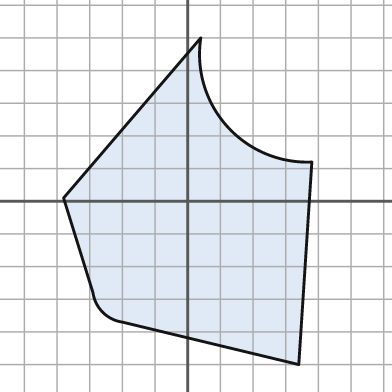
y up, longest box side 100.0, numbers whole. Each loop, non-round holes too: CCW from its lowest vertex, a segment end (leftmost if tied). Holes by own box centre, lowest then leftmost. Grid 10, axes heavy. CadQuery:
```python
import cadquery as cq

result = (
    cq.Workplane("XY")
    .moveTo(34.0, -50.0)
    .lineTo(38.0, 12.0)
    .threePointArc((12.0, 23.0), (4.0, 50.0))
    .lineTo(-38.0, 1.0)
    .lineTo(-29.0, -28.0)
    .threePointArc((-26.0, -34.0), (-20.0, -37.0))
    .close()
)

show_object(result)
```